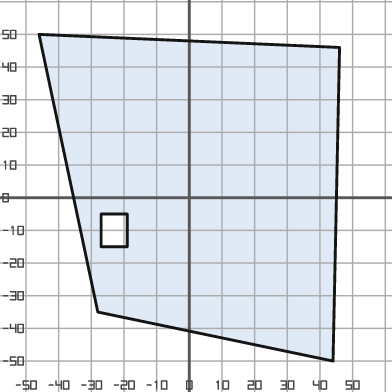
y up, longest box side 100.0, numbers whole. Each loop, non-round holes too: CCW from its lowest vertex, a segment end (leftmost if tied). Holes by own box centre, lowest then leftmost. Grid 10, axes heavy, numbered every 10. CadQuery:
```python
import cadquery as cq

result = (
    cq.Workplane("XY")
    .moveTo(44.0, -50.0)
    .lineTo(46.0, 46.0)
    .lineTo(-46.0, 50.0)
    .lineTo(-28.0, -35.0)
    .close()
    .moveTo(-27.0, -15.0)
    .lineTo(-19.0, -15.0)
    .lineTo(-19.0, -5.0)
    .lineTo(-27.0, -5.0)
    .close()
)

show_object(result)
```